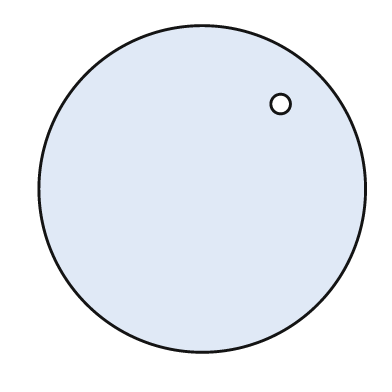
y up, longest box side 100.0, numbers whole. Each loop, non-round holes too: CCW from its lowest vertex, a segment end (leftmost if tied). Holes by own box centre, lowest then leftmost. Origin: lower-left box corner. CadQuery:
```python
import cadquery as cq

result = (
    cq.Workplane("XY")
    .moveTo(50.0, 50.0)
    .circle(50.0)
    .moveTo(74.0, 76.0)
    .circle(3.0)
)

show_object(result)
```